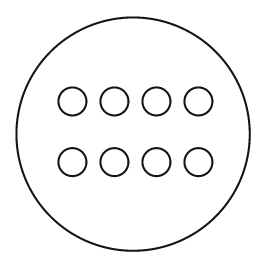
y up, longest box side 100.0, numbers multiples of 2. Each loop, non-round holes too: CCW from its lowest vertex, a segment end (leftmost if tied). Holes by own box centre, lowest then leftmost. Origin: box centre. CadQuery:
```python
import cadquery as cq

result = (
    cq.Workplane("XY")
    .moveTo(0.0, 0.0)
    .circle(50.0)
    .moveTo(-26.0, -12.0)
    .circle(6.0)
    .moveTo(-8.0, -12.0)
    .circle(6.0)
    .moveTo(10.0, -12.0)
    .circle(6.0)
    .moveTo(28.0, -12.0)
    .circle(6.0)
    .moveTo(-26.0, 14.0)
    .circle(6.0)
    .moveTo(-8.0, 14.0)
    .circle(6.0)
    .moveTo(10.0, 14.0)
    .circle(6.0)
    .moveTo(28.0, 14.0)
    .circle(6.0)
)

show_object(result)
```